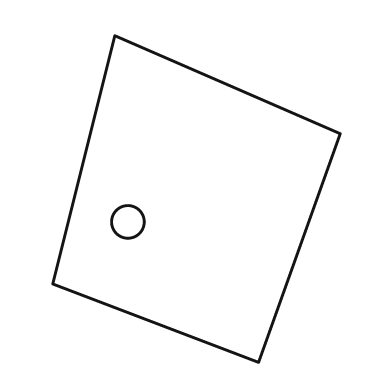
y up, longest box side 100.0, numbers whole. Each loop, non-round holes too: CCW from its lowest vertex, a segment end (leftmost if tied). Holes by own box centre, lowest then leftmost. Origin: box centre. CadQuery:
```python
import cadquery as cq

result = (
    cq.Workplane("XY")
    .moveTo(19.0, -50.0)
    .lineTo(44.0, 20.0)
    .lineTo(-25.0, 50.0)
    .lineTo(-44.0, -26.0)
    .close()
    .moveTo(-21.0, -7.0)
    .circle(5.0)
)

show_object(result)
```